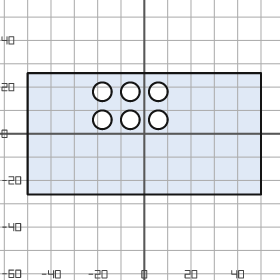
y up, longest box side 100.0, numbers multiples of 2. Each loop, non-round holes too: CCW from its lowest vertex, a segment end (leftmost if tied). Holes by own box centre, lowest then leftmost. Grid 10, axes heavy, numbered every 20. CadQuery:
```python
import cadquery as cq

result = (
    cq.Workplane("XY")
    .moveTo(-50.0, -26.0)
    .lineTo(50.0, -26.0)
    .lineTo(50.0, 26.0)
    .lineTo(-50.0, 26.0)
    .close()
    .moveTo(-18.0, 6.0)
    .circle(4.0)
    .moveTo(-6.0, 6.0)
    .circle(4.0)
    .moveTo(6.0, 6.0)
    .circle(4.0)
    .moveTo(-18.0, 18.0)
    .circle(4.0)
    .moveTo(-6.0, 18.0)
    .circle(4.0)
    .moveTo(6.0, 18.0)
    .circle(4.0)
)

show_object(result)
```